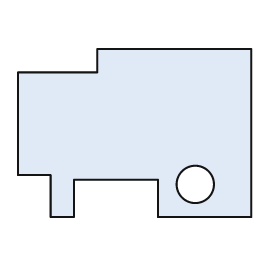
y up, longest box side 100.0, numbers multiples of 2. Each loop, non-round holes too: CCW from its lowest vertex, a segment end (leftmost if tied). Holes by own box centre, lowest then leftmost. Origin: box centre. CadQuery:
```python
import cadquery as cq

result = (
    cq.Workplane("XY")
    .moveTo(-36.0, -36.0)
    .lineTo(-26.0, -36.0)
    .lineTo(-26.0, -20.0)
    .lineTo(10.0, -20.0)
    .lineTo(10.0, -36.0)
    .lineTo(50.0, -36.0)
    .lineTo(50.0, 36.0)
    .lineTo(-16.0, 36.0)
    .lineTo(-16.0, 26.0)
    .lineTo(-50.0, 26.0)
    .lineTo(-50.0, -18.0)
    .lineTo(-36.0, -18.0)
    .close()
    .moveTo(26.0, -22.0)
    .circle(8.0)
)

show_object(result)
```